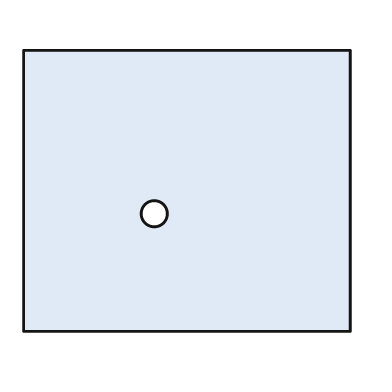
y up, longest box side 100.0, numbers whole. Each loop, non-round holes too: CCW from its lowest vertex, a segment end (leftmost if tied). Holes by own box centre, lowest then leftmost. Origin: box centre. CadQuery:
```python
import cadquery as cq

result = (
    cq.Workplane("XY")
    .moveTo(-50.0, -43.0)
    .lineTo(50.0, -43.0)
    .lineTo(50.0, 43.0)
    .lineTo(-50.0, 43.0)
    .close()
    .moveTo(-10.0, -7.0)
    .circle(4.0)
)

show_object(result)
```